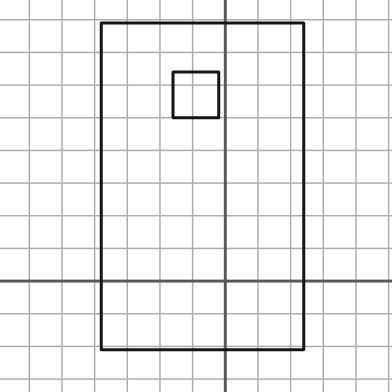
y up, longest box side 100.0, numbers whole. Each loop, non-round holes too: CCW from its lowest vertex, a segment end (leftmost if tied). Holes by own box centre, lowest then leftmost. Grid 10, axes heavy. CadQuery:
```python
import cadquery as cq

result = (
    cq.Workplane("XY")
    .moveTo(-38.0, -21.0)
    .lineTo(24.0, -21.0)
    .lineTo(24.0, 79.0)
    .lineTo(-38.0, 79.0)
    .close()
    .moveTo(-16.0, 50.0)
    .lineTo(-2.0, 50.0)
    .lineTo(-2.0, 64.0)
    .lineTo(-16.0, 64.0)
    .close()
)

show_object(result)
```